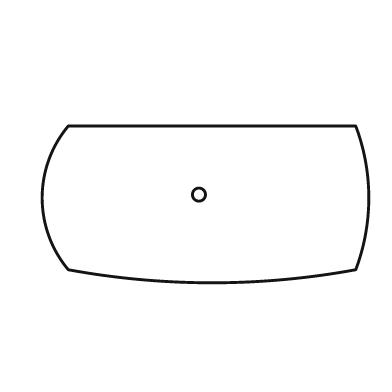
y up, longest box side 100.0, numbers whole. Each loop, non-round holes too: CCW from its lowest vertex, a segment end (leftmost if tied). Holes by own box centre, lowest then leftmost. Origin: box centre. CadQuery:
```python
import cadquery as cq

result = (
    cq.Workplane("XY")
    .moveTo(-42.0, -20.0)
    .threePointArc((2.0, -24.0), (46.0, -20.0))
    .threePointArc((50.0, 2.0), (46.0, 24.0))
    .lineTo(-42.0, 24.0)
    .threePointArc((-50.0, 2.0), (-42.0, -20.0))
    .close()
    .moveTo(-2.0, 3.0)
    .circle(2.0)
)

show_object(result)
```